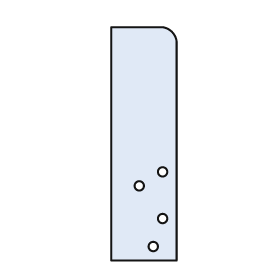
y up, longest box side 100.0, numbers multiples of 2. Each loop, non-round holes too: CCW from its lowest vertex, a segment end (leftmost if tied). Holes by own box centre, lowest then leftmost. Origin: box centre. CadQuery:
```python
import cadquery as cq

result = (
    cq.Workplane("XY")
    .moveTo(-14.0, -50.0)
    .lineTo(14.0, -50.0)
    .lineTo(14.0, 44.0)
    .threePointArc((12.0, 48.0), (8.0, 50.0))
    .lineTo(-14.0, 50.0)
    .close()
    .moveTo(4.0, -44.0)
    .circle(2.0)
    .moveTo(8.0, -32.0)
    .circle(2.0)
    .moveTo(-2.0, -18.0)
    .circle(2.0)
    .moveTo(8.0, -12.0)
    .circle(2.0)
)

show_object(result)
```